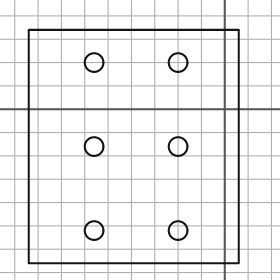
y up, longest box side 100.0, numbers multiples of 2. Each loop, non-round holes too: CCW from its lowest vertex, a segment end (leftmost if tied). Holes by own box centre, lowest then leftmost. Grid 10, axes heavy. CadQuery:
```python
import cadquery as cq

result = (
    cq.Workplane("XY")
    .moveTo(-84.0, -66.0)
    .lineTo(6.0, -66.0)
    .lineTo(6.0, 34.0)
    .lineTo(-84.0, 34.0)
    .close()
    .moveTo(-56.0, -52.0)
    .circle(4.0)
    .moveTo(-20.0, -52.0)
    .circle(4.0)
    .moveTo(-56.0, -16.0)
    .circle(4.0)
    .moveTo(-20.0, -16.0)
    .circle(4.0)
    .moveTo(-56.0, 20.0)
    .circle(4.0)
    .moveTo(-20.0, 20.0)
    .circle(4.0)
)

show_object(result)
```